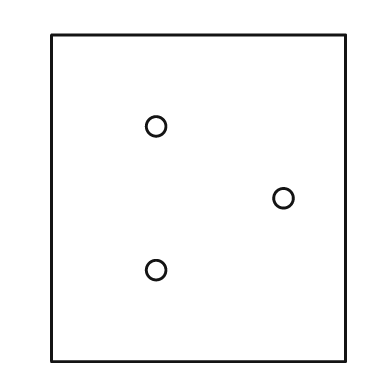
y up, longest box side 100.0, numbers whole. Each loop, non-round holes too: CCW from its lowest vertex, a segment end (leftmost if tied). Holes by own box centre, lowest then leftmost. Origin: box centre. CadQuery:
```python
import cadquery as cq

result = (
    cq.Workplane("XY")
    .moveTo(-45.0, -50.0)
    .lineTo(45.0, -50.0)
    .lineTo(45.0, 50.0)
    .lineTo(-45.0, 50.0)
    .close()
    .moveTo(-13.0, -22.0)
    .circle(3.0)
    .moveTo(26.0, 0.0)
    .circle(3.0)
    .moveTo(-13.0, 22.0)
    .circle(3.0)
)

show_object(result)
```